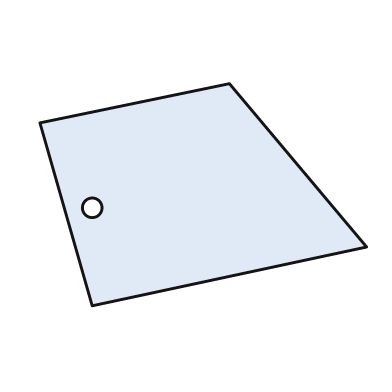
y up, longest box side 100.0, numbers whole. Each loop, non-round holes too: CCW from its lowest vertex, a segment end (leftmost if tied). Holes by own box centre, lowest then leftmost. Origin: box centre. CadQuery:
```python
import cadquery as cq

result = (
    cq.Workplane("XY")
    .moveTo(-34.0, -34.0)
    .lineTo(50.0, -16.0)
    .lineTo(8.0, 34.0)
    .lineTo(-50.0, 22.0)
    .close()
    .moveTo(-34.0, -4.0)
    .circle(3.0)
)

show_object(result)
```